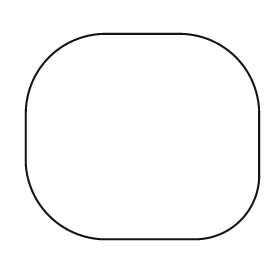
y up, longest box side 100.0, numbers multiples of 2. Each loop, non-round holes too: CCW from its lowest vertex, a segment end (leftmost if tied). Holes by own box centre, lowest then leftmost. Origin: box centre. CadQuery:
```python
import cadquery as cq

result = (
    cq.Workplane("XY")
    .moveTo(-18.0, -44.0)
    .lineTo(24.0, -44.0)
    .threePointArc((42.0, -36.0), (50.0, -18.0))
    .lineTo(50.0, 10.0)
    .threePointArc((40.0, 34.0), (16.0, 44.0))
    .lineTo(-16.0, 44.0)
    .threePointArc((-40.0, 34.0), (-50.0, 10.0))
    .lineTo(-50.0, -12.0)
    .threePointArc((-40.0, -34.0), (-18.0, -44.0))
    .close()
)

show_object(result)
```